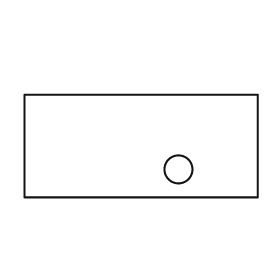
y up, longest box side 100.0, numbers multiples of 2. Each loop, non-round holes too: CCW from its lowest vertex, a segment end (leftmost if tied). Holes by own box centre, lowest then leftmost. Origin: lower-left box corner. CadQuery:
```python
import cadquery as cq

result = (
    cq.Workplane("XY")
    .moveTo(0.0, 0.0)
    .lineTo(100.0, 0.0)
    .lineTo(100.0, 44.0)
    .lineTo(0.0, 44.0)
    .close()
    .moveTo(66.0, 12.0)
    .circle(6.0)
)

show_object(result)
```